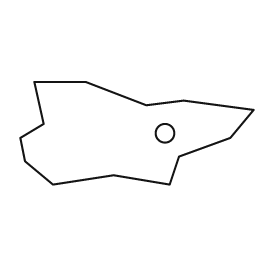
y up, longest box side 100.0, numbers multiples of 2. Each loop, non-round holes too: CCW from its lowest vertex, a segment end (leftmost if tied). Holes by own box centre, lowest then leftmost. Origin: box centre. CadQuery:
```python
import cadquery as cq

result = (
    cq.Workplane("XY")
    .moveTo(-36.0, -22.0)
    .lineTo(-10.0, -18.0)
    .lineTo(14.0, -22.0)
    .lineTo(18.0, -10.0)
    .lineTo(40.0, -2.0)
    .lineTo(50.0, 10.0)
    .lineTo(20.0, 14.0)
    .lineTo(4.0, 12.0)
    .lineTo(-22.0, 22.0)
    .lineTo(-44.0, 22.0)
    .lineTo(-40.0, 4.0)
    .lineTo(-50.0, -2.0)
    .lineTo(-48.0, -12.0)
    .close()
    .moveTo(12.0, 0.0)
    .circle(4.0)
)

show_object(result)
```